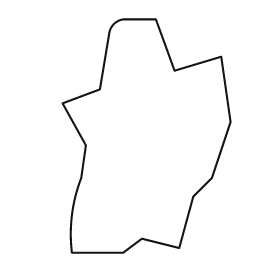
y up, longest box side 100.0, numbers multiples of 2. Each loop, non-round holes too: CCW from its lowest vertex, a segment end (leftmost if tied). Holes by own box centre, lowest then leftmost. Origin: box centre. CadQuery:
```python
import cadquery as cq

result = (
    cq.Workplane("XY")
    .moveTo(-32.0, -50.0)
    .lineTo(-10.0, -50.0)
    .lineTo(-2.0, -44.0)
    .lineTo(14.0, -48.0)
    .lineTo(20.0, -26.0)
    .lineTo(28.0, -18.0)
    .lineTo(36.0, 6.0)
    .lineTo(32.0, 34.0)
    .lineTo(12.0, 28.0)
    .lineTo(4.0, 50.0)
    .lineTo(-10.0, 50.0)
    .threePointArc((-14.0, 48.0), (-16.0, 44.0))
    .lineTo(-20.0, 20.0)
    .lineTo(-36.0, 14.0)
    .lineTo(-26.0, -4.0)
    .lineTo(-28.0, -18.0)
    .threePointArc((-32.0, -34.0), (-32.0, -50.0))
    .close()
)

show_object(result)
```